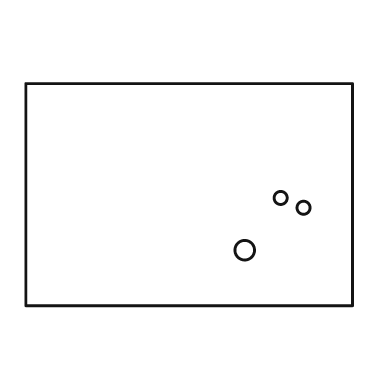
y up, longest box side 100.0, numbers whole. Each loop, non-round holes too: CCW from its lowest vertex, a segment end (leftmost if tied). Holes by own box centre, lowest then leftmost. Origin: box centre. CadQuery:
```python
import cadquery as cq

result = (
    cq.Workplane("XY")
    .moveTo(-50.0, -34.0)
    .lineTo(50.0, -34.0)
    .lineTo(50.0, 34.0)
    .lineTo(-50.0, 34.0)
    .close()
    .moveTo(17.0, -17.0)
    .circle(3.0)
    .moveTo(35.0, -4.0)
    .circle(2.0)
    .moveTo(28.0, -1.0)
    .circle(2.0)
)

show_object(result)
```